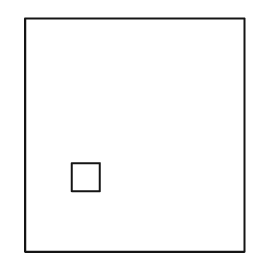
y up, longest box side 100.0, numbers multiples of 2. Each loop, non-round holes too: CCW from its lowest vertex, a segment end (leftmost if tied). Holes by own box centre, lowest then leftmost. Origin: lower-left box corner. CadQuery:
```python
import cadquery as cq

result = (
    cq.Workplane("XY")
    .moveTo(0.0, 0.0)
    .lineTo(94.0, 0.0)
    .lineTo(94.0, 100.0)
    .lineTo(0.0, 100.0)
    .close()
    .moveTo(20.0, 26.0)
    .lineTo(32.0, 26.0)
    .lineTo(32.0, 38.0)
    .lineTo(20.0, 38.0)
    .close()
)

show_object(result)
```